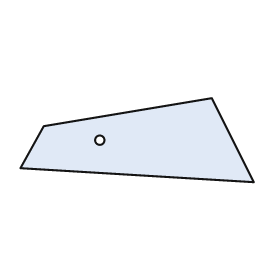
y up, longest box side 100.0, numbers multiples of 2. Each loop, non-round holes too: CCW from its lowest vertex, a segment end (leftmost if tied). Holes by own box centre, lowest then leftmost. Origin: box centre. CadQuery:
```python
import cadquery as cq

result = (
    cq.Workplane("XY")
    .moveTo(50.0, -18.0)
    .lineTo(32.0, 18.0)
    .lineTo(-40.0, 6.0)
    .lineTo(-50.0, -12.0)
    .close()
    .moveTo(-16.0, 0.0)
    .circle(2.0)
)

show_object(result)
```